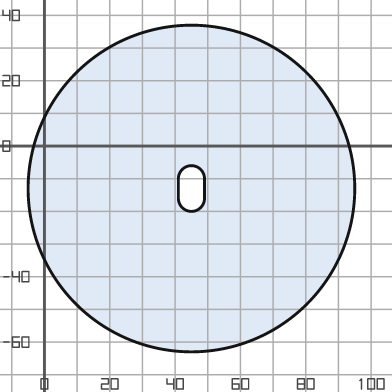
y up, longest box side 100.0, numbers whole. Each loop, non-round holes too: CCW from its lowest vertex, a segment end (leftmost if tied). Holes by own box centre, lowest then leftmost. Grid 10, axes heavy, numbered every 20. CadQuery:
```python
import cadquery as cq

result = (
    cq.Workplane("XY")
    .moveTo(45.0, -13.0)
    .circle(50.0)
    .moveTo(41.0, -16.0)
    .threePointArc((45.0, -20.0), (49.0, -16.0))
    .lineTo(49.0, -10.0)
    .threePointArc((45.0, -6.0), (41.0, -10.0))
    .close()
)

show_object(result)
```